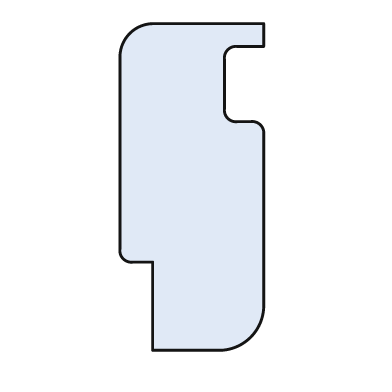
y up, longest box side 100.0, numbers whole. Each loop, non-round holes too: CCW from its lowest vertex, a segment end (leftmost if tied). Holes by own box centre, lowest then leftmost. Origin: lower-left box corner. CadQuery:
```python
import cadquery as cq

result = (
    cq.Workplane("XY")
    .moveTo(10.0, 0.0)
    .lineTo(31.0, 0.0)
    .threePointArc((40.0, 4.0), (44.0, 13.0))
    .lineTo(44.0, 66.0)
    .threePointArc((43.0, 69.0), (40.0, 70.0))
    .lineTo(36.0, 70.0)
    .threePointArc((33.0, 71.0), (32.0, 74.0))
    .lineTo(32.0, 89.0)
    .threePointArc((33.0, 92.0), (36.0, 93.0))
    .lineTo(44.0, 93.0)
    .lineTo(44.0, 100.0)
    .lineTo(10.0, 100.0)
    .threePointArc((3.0, 97.0), (0.0, 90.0))
    .lineTo(0.0, 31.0)
    .threePointArc((1.0, 28.0), (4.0, 27.0))
    .lineTo(10.0, 27.0)
    .close()
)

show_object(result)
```